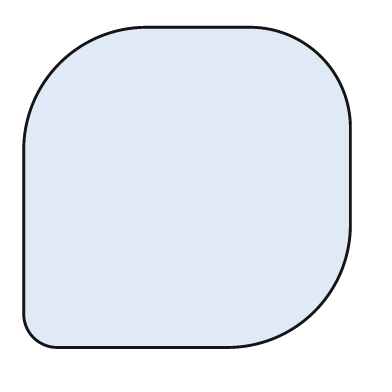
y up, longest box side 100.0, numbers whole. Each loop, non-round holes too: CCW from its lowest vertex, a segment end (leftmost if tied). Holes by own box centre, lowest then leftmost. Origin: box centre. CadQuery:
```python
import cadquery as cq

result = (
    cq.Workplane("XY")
    .moveTo(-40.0, -49.0)
    .lineTo(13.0, -49.0)
    .threePointArc((39.0, -38.0), (50.0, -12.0))
    .lineTo(50.0, 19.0)
    .threePointArc((41.0, 40.0), (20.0, 49.0))
    .lineTo(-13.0, 49.0)
    .threePointArc((-39.0, 38.0), (-50.0, 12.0))
    .lineTo(-50.0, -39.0)
    .threePointArc((-47.0, -46.0), (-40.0, -49.0))
    .close()
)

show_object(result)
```